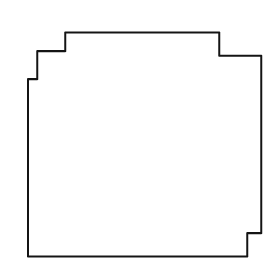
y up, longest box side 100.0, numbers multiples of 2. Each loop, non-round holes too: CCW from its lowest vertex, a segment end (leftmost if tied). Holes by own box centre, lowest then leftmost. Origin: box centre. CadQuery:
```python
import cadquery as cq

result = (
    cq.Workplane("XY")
    .moveTo(-50.0, -48.0)
    .lineTo(44.0, -48.0)
    .lineTo(44.0, -38.0)
    .lineTo(50.0, -38.0)
    .lineTo(50.0, 38.0)
    .lineTo(32.0, 38.0)
    .lineTo(32.0, 48.0)
    .lineTo(-34.0, 48.0)
    .lineTo(-34.0, 40.0)
    .lineTo(-46.0, 40.0)
    .lineTo(-46.0, 28.0)
    .lineTo(-50.0, 28.0)
    .close()
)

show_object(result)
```